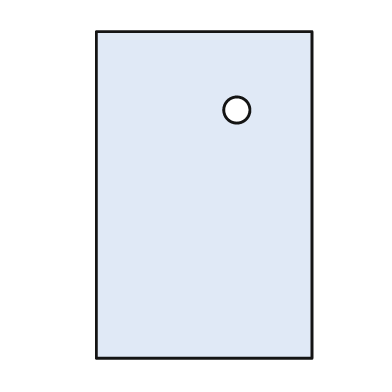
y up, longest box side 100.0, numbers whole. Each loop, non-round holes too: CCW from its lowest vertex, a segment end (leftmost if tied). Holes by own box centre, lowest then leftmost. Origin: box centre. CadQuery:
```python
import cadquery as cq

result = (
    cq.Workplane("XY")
    .moveTo(-33.0, -50.0)
    .lineTo(33.0, -50.0)
    .lineTo(33.0, 50.0)
    .lineTo(-33.0, 50.0)
    .close()
    .moveTo(10.0, 26.0)
    .circle(4.0)
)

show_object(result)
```